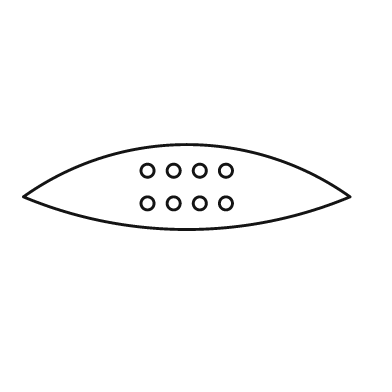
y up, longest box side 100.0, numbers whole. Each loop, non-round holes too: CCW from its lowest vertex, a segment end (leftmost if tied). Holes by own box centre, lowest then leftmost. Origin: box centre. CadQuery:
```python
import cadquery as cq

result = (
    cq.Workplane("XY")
    .moveTo(-50.0, -3.0)
    .threePointArc((0.0, -13.0), (50.0, -3.0))
    .threePointArc((0.0, 13.0), (-50.0, -3.0))
    .close()
    .moveTo(-12.0, -5.0)
    .circle(2.0)
    .moveTo(-4.0, -5.0)
    .circle(2.0)
    .moveTo(4.0, -5.0)
    .circle(2.0)
    .moveTo(12.0, -5.0)
    .circle(2.0)
    .moveTo(-12.0, 5.0)
    .circle(2.0)
    .moveTo(-4.0, 5.0)
    .circle(2.0)
    .moveTo(4.0, 5.0)
    .circle(2.0)
    .moveTo(12.0, 5.0)
    .circle(2.0)
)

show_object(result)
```